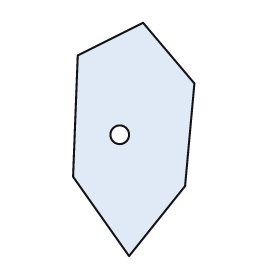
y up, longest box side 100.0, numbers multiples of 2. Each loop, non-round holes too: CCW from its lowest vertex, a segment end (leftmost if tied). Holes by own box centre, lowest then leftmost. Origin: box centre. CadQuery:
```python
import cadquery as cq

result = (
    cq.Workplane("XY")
    .moveTo(-2.0, -50.0)
    .lineTo(22.0, -20.0)
    .lineTo(26.0, 24.0)
    .lineTo(4.0, 50.0)
    .lineTo(-24.0, 36.0)
    .lineTo(-26.0, -16.0)
    .close()
    .moveTo(-6.0, 2.0)
    .circle(4.0)
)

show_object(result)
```